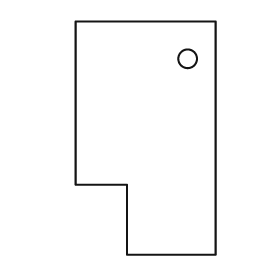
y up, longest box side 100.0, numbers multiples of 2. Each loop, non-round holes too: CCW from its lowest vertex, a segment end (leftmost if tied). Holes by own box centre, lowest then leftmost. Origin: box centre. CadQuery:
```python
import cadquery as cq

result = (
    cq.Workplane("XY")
    .moveTo(-8.0, -50.0)
    .lineTo(30.0, -50.0)
    .lineTo(30.0, 50.0)
    .lineTo(-30.0, 50.0)
    .lineTo(-30.0, -20.0)
    .lineTo(-8.0, -20.0)
    .close()
    .moveTo(18.0, 34.0)
    .circle(4.0)
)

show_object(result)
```